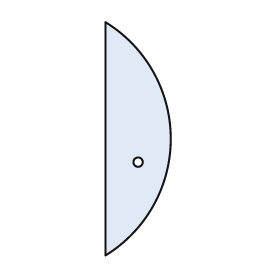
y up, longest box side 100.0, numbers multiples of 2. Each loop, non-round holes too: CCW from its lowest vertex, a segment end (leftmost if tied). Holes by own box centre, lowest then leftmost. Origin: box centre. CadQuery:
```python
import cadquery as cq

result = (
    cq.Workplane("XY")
    .moveTo(-14.0, -50.0)
    .threePointArc((14.0, 0.0), (-14.0, 50.0))
    .close()
    .moveTo(0.0, -10.0)
    .circle(2.0)
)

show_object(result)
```